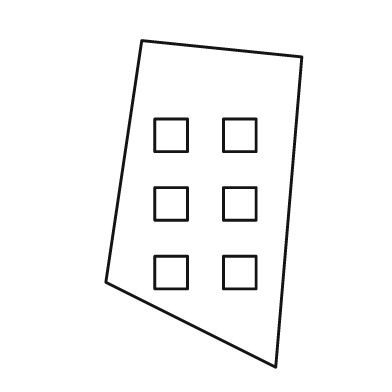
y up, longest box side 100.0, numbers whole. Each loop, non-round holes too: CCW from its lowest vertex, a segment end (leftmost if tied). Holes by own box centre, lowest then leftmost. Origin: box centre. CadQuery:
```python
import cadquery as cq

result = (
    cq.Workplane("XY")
    .moveTo(22.0, -50.0)
    .lineTo(30.0, 45.0)
    .lineTo(-19.0, 50.0)
    .lineTo(-30.0, -24.0)
    .close()
    .moveTo(-15.0, -26.0)
    .lineTo(-5.0, -26.0)
    .lineTo(-5.0, -16.0)
    .lineTo(-15.0, -16.0)
    .close()
    .moveTo(6.0, -26.0)
    .lineTo(16.0, -26.0)
    .lineTo(16.0, -16.0)
    .lineTo(6.0, -16.0)
    .close()
    .moveTo(-15.0, -5.0)
    .lineTo(-5.0, -5.0)
    .lineTo(-5.0, 5.0)
    .lineTo(-15.0, 5.0)
    .close()
    .moveTo(6.0, -5.0)
    .lineTo(16.0, -5.0)
    .lineTo(16.0, 5.0)
    .lineTo(6.0, 5.0)
    .close()
    .moveTo(-15.0, 16.0)
    .lineTo(-5.0, 16.0)
    .lineTo(-5.0, 26.0)
    .lineTo(-15.0, 26.0)
    .close()
    .moveTo(6.0, 16.0)
    .lineTo(16.0, 16.0)
    .lineTo(16.0, 26.0)
    .lineTo(6.0, 26.0)
    .close()
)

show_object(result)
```